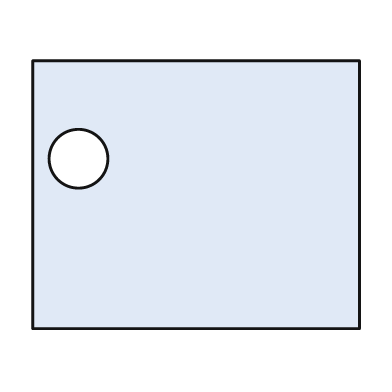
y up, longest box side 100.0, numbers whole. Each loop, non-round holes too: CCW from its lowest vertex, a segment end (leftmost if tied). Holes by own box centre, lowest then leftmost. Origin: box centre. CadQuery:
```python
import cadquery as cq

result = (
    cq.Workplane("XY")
    .moveTo(-50.0, -41.0)
    .lineTo(50.0, -41.0)
    .lineTo(50.0, 41.0)
    .lineTo(-50.0, 41.0)
    .close()
    .moveTo(-36.0, 11.0)
    .circle(9.0)
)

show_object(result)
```